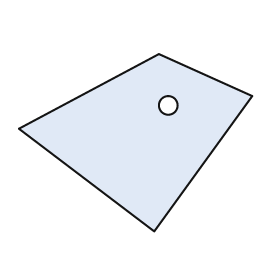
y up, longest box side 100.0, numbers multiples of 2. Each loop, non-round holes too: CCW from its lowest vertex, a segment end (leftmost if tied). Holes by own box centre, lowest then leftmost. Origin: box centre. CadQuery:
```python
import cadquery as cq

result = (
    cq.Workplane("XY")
    .moveTo(8.0, -38.0)
    .lineTo(50.0, 20.0)
    .lineTo(10.0, 38.0)
    .lineTo(-50.0, 6.0)
    .close()
    .moveTo(14.0, 16.0)
    .circle(4.0)
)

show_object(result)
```